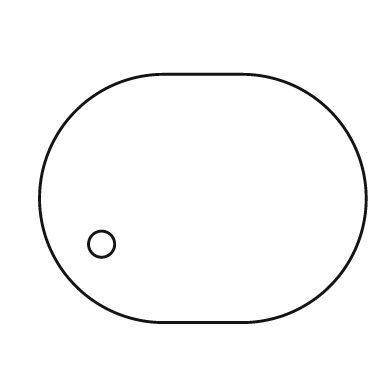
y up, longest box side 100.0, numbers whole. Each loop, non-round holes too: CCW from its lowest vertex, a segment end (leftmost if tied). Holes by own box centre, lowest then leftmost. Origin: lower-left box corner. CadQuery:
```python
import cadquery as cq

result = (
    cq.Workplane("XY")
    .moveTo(38.0, 0.0)
    .lineTo(62.0, 0.0)
    .threePointArc((100.0, 38.0), (62.0, 76.0))
    .lineTo(38.0, 76.0)
    .threePointArc((0.0, 38.0), (38.0, 0.0))
    .close()
    .moveTo(19.0, 24.0)
    .circle(4.0)
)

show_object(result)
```